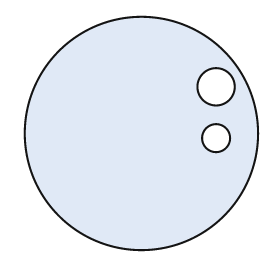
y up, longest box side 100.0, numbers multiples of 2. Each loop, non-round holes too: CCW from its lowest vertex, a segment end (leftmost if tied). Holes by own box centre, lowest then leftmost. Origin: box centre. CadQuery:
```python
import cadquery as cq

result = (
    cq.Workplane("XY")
    .moveTo(0.0, 0.0)
    .circle(50.0)
    .moveTo(32.0, -2.0)
    .circle(6.0)
    .moveTo(32.0, 20.0)
    .circle(8.0)
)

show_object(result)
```